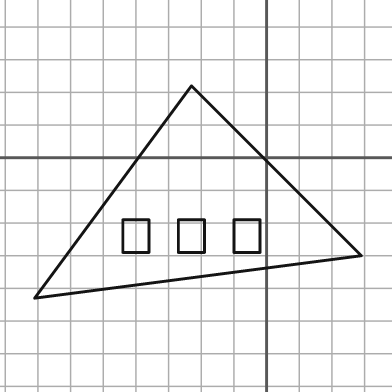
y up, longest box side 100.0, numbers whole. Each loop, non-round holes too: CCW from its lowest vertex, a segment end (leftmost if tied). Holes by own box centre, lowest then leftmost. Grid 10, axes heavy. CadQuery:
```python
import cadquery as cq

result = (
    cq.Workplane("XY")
    .moveTo(-71.0, -43.0)
    .lineTo(29.0, -30.0)
    .lineTo(-23.0, 22.0)
    .close()
    .moveTo(-44.0, -29.0)
    .lineTo(-36.0, -29.0)
    .lineTo(-36.0, -19.0)
    .lineTo(-44.0, -19.0)
    .close()
    .moveTo(-27.0, -29.0)
    .lineTo(-19.0, -29.0)
    .lineTo(-19.0, -19.0)
    .lineTo(-27.0, -19.0)
    .close()
    .moveTo(-10.0, -29.0)
    .lineTo(-2.0, -29.0)
    .lineTo(-2.0, -19.0)
    .lineTo(-10.0, -19.0)
    .close()
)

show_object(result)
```